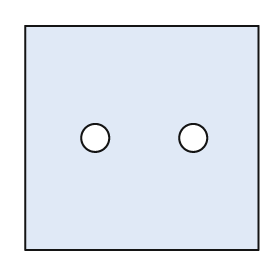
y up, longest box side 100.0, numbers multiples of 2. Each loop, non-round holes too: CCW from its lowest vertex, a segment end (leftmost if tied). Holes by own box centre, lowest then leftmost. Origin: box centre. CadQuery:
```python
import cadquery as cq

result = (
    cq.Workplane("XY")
    .moveTo(-50.0, -48.0)
    .lineTo(50.0, -48.0)
    .lineTo(50.0, 48.0)
    .lineTo(-50.0, 48.0)
    .close()
    .moveTo(-20.0, 0.0)
    .circle(6.0)
    .moveTo(22.0, 0.0)
    .circle(6.0)
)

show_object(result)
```